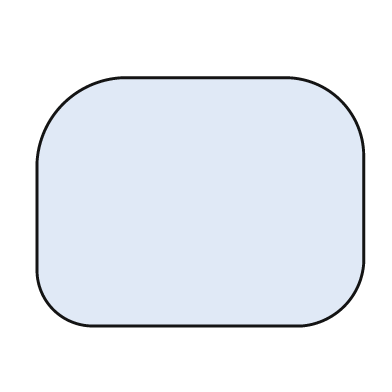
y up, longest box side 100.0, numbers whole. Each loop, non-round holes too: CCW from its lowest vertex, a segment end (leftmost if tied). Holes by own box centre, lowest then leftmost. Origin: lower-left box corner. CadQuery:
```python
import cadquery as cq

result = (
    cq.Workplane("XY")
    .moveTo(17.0, 0.0)
    .lineTo(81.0, 0.0)
    .threePointArc((94.0, 6.0), (100.0, 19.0))
    .lineTo(100.0, 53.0)
    .threePointArc((93.0, 69.0), (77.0, 76.0))
    .lineTo(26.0, 76.0)
    .threePointArc((8.0, 68.0), (0.0, 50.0))
    .lineTo(0.0, 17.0)
    .threePointArc((5.0, 5.0), (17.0, 0.0))
    .close()
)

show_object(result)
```